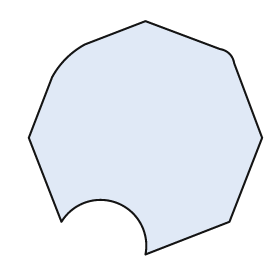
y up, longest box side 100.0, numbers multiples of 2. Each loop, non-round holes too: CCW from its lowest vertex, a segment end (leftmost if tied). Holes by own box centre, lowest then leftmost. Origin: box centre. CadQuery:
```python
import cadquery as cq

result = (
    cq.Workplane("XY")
    .moveTo(0.0, -50.0)
    .lineTo(36.0, -36.0)
    .lineTo(50.0, 0.0)
    .lineTo(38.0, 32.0)
    .threePointArc((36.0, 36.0), (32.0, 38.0))
    .lineTo(0.0, 50.0)
    .lineTo(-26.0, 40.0)
    .threePointArc((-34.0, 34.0), (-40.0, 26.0))
    .lineTo(-50.0, 0.0)
    .lineTo(-36.0, -36.0)
    .threePointArc((-12.0, -28.0), (0.0, -50.0))
    .close()
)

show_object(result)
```